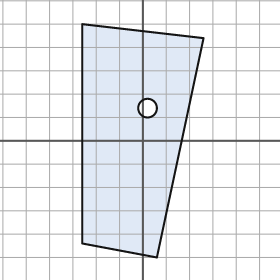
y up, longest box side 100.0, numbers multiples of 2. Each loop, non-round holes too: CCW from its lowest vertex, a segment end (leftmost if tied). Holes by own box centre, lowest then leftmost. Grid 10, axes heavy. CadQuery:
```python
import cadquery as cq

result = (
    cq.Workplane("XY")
    .moveTo(6.0, -50.0)
    .lineTo(26.0, 44.0)
    .lineTo(-26.0, 50.0)
    .lineTo(-26.0, -44.0)
    .close()
    .moveTo(2.0, 14.0)
    .circle(4.0)
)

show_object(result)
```